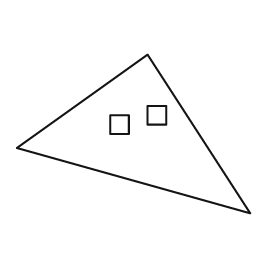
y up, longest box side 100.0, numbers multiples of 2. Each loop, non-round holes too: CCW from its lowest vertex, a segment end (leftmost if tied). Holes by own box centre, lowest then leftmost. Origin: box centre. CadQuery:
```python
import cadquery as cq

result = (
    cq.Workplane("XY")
    .moveTo(50.0, -34.0)
    .lineTo(6.0, 34.0)
    .lineTo(-50.0, -6.0)
    .close()
    .moveTo(-10.0, 0.0)
    .lineTo(-2.0, 0.0)
    .lineTo(-2.0, 8.0)
    .lineTo(-10.0, 8.0)
    .close()
    .moveTo(6.0, 4.0)
    .lineTo(14.0, 4.0)
    .lineTo(14.0, 12.0)
    .lineTo(6.0, 12.0)
    .close()
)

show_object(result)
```